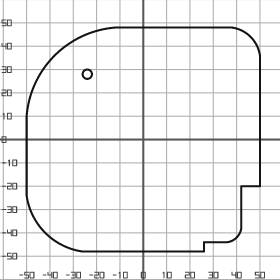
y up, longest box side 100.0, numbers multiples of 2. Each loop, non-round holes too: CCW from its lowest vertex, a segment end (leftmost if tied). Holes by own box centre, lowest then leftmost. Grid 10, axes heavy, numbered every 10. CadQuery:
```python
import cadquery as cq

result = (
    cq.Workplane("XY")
    .moveTo(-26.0, -48.0)
    .lineTo(26.0, -48.0)
    .lineTo(26.0, -44.0)
    .lineTo(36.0, -44.0)
    .threePointArc((40.0, -42.0), (42.0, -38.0))
    .lineTo(42.0, -20.0)
    .lineTo(50.0, -20.0)
    .lineTo(50.0, 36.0)
    .threePointArc((46.0, 44.0), (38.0, 48.0))
    .lineTo(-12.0, 48.0)
    .threePointArc((-38.0, 36.0), (-50.0, 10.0))
    .lineTo(-50.0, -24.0)
    .threePointArc((-42.0, -40.0), (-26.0, -48.0))
    .close()
    .moveTo(-24.0, 28.0)
    .circle(2.0)
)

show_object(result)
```